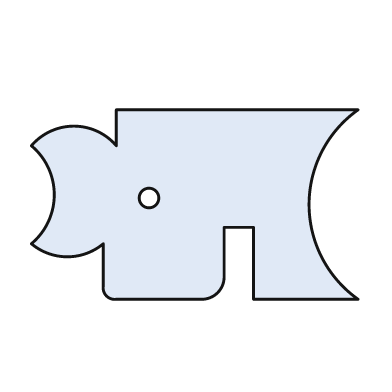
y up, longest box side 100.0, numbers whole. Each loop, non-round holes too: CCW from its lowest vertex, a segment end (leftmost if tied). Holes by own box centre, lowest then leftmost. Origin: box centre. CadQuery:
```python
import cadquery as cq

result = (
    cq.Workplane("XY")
    .moveTo(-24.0, -29.0)
    .lineTo(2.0, -29.0)
    .threePointArc((7.0, -27.0), (9.0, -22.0))
    .lineTo(9.0, -7.0)
    .lineTo(18.0, -7.0)
    .lineTo(18.0, -29.0)
    .lineTo(50.0, -29.0)
    .threePointArc((35.0, 0.0), (50.0, 29.0))
    .lineTo(-24.0, 29.0)
    .lineTo(-24.0, 18.0)
    .threePointArc((-37.0, 24.0), (-50.0, 18.0))
    .threePointArc((-43.0, 3.0), (-50.0, -12.0))
    .threePointArc((-39.0, -16.0), (-28.0, -12.0))
    .lineTo(-28.0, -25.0)
    .threePointArc((-27.0, -28.0), (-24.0, -29.0))
    .close()
    .moveTo(-14.0, 2.0)
    .circle(3.0)
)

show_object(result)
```